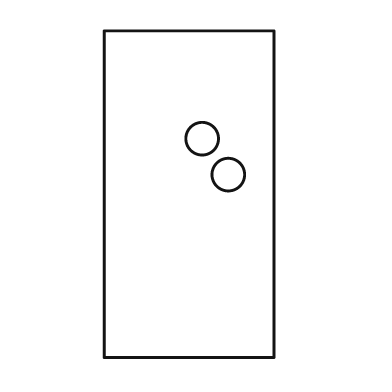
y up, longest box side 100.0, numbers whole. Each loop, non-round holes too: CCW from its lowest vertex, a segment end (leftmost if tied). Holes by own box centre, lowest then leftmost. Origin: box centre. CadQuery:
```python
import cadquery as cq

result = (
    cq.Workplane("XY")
    .moveTo(-26.0, -50.0)
    .lineTo(26.0, -50.0)
    .lineTo(26.0, 50.0)
    .lineTo(-26.0, 50.0)
    .close()
    .moveTo(12.0, 6.0)
    .circle(5.0)
    .moveTo(4.0, 17.0)
    .circle(5.0)
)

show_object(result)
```